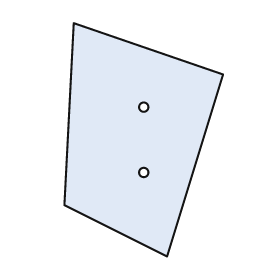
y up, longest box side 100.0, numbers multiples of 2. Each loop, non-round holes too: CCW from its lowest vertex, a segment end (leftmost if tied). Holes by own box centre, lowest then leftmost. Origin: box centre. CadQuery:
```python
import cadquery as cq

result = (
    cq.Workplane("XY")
    .moveTo(10.0, -50.0)
    .lineTo(34.0, 28.0)
    .lineTo(-30.0, 50.0)
    .lineTo(-34.0, -28.0)
    .close()
    .moveTo(0.0, -14.0)
    .circle(2.0)
    .moveTo(0.0, 14.0)
    .circle(2.0)
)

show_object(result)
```